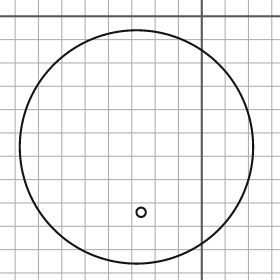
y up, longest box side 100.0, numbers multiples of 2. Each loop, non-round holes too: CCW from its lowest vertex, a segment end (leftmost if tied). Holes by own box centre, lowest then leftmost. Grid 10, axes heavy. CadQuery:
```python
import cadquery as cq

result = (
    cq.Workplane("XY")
    .moveTo(-28.0, -56.0)
    .circle(50.0)
    .moveTo(-26.0, -84.0)
    .circle(2.0)
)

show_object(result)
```